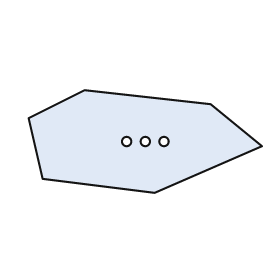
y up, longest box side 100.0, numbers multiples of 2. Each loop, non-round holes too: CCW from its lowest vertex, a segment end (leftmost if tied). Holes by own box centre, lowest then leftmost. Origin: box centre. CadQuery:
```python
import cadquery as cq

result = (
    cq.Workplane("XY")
    .moveTo(4.0, -22.0)
    .lineTo(50.0, -2.0)
    .lineTo(28.0, 16.0)
    .lineTo(-26.0, 22.0)
    .lineTo(-50.0, 10.0)
    .lineTo(-44.0, -16.0)
    .close()
    .moveTo(-8.0, 0.0)
    .circle(2.0)
    .moveTo(0.0, 0.0)
    .circle(2.0)
    .moveTo(8.0, 0.0)
    .circle(2.0)
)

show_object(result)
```